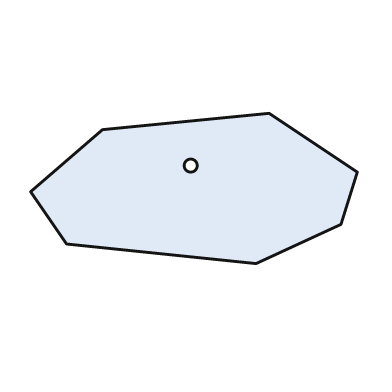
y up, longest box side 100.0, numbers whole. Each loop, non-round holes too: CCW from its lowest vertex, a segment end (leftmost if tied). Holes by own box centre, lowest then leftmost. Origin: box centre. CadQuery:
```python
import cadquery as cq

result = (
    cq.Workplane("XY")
    .moveTo(19.0, -23.0)
    .lineTo(45.0, -11.0)
    .lineTo(50.0, 5.0)
    .lineTo(23.0, 23.0)
    .lineTo(-28.0, 18.0)
    .lineTo(-50.0, -1.0)
    .lineTo(-39.0, -17.0)
    .close()
    .moveTo(-1.0, 7.0)
    .circle(2.0)
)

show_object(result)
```